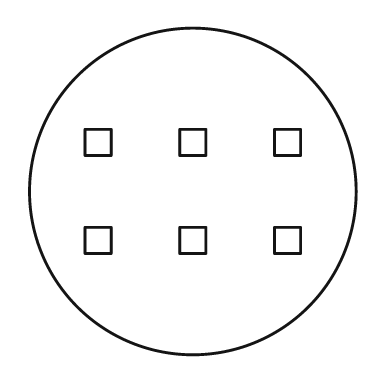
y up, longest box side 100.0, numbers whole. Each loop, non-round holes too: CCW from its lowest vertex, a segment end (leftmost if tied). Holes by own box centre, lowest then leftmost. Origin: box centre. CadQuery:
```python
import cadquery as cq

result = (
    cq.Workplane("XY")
    .moveTo(0.0, 0.0)
    .circle(50.0)
    .moveTo(-33.0, -19.0)
    .lineTo(-25.0, -19.0)
    .lineTo(-25.0, -11.0)
    .lineTo(-33.0, -11.0)
    .close()
    .moveTo(-4.0, -19.0)
    .lineTo(4.0, -19.0)
    .lineTo(4.0, -11.0)
    .lineTo(-4.0, -11.0)
    .close()
    .moveTo(25.0, -19.0)
    .lineTo(33.0, -19.0)
    .lineTo(33.0, -11.0)
    .lineTo(25.0, -11.0)
    .close()
    .moveTo(-33.0, 11.0)
    .lineTo(-25.0, 11.0)
    .lineTo(-25.0, 19.0)
    .lineTo(-33.0, 19.0)
    .close()
    .moveTo(-4.0, 11.0)
    .lineTo(4.0, 11.0)
    .lineTo(4.0, 19.0)
    .lineTo(-4.0, 19.0)
    .close()
    .moveTo(25.0, 11.0)
    .lineTo(33.0, 11.0)
    .lineTo(33.0, 19.0)
    .lineTo(25.0, 19.0)
    .close()
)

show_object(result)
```